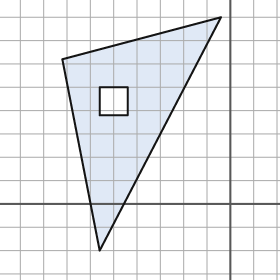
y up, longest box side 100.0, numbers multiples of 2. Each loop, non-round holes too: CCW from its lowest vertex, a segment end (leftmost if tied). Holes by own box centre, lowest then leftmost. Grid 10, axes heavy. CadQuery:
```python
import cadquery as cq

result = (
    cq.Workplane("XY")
    .moveTo(-56.0, -20.0)
    .lineTo(-4.0, 80.0)
    .lineTo(-72.0, 62.0)
    .close()
    .moveTo(-56.0, 38.0)
    .lineTo(-44.0, 38.0)
    .lineTo(-44.0, 50.0)
    .lineTo(-56.0, 50.0)
    .close()
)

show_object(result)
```